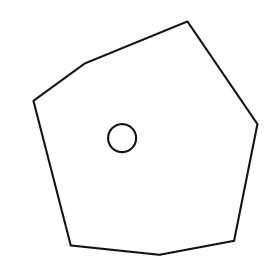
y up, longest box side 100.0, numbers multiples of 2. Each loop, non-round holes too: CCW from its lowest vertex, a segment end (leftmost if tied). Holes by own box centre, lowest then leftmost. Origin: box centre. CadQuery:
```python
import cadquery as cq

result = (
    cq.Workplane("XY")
    .moveTo(6.0, -50.0)
    .lineTo(38.0, -44.0)
    .lineTo(48.0, 6.0)
    .lineTo(18.0, 50.0)
    .lineTo(-26.0, 32.0)
    .lineTo(-48.0, 16.0)
    .lineTo(-32.0, -46.0)
    .close()
    .moveTo(-10.0, 0.0)
    .circle(6.0)
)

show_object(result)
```